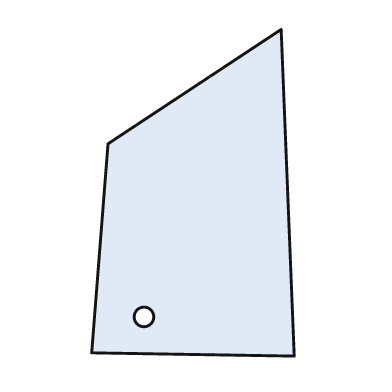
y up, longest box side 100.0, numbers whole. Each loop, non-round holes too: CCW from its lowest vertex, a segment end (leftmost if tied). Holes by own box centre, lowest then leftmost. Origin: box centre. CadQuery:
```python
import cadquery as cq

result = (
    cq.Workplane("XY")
    .moveTo(31.0, -50.0)
    .lineTo(27.0, 50.0)
    .lineTo(-26.0, 15.0)
    .lineTo(-31.0, -49.0)
    .close()
    .moveTo(-15.0, -38.0)
    .circle(3.0)
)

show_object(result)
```